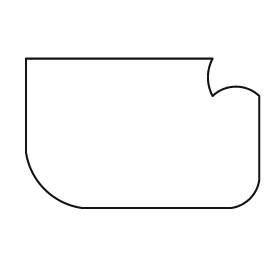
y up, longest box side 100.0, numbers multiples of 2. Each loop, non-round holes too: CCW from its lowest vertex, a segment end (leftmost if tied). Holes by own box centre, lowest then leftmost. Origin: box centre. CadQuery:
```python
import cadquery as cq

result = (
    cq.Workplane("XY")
    .moveTo(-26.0, -32.0)
    .lineTo(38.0, -32.0)
    .threePointArc((46.0, -28.0), (50.0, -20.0))
    .lineTo(50.0, 16.0)
    .threePointArc((40.0, 20.0), (30.0, 16.0))
    .threePointArc((28.0, 24.0), (30.0, 32.0))
    .lineTo(-50.0, 32.0)
    .lineTo(-50.0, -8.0)
    .threePointArc((-42.0, -24.0), (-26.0, -32.0))
    .close()
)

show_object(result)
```